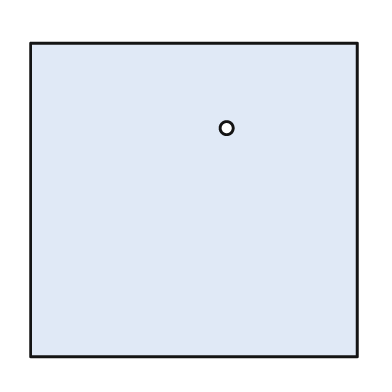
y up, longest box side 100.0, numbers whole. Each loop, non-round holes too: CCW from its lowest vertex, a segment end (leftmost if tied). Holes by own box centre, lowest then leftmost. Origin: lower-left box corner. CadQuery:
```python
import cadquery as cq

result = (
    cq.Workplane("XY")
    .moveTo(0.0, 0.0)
    .lineTo(100.0, 0.0)
    .lineTo(100.0, 96.0)
    .lineTo(0.0, 96.0)
    .close()
    .moveTo(60.0, 70.0)
    .circle(2.0)
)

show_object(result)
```